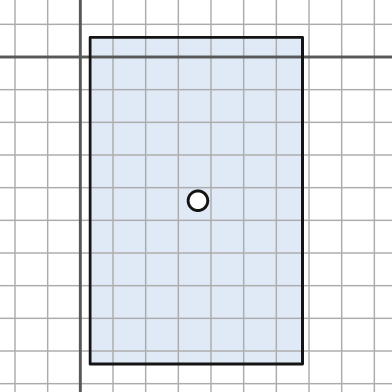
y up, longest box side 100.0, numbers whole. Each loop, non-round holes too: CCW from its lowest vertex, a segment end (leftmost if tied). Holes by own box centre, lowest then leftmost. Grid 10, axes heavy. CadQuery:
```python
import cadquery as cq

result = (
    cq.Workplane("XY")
    .moveTo(3.0, -94.0)
    .lineTo(68.0, -94.0)
    .lineTo(68.0, 6.0)
    .lineTo(3.0, 6.0)
    .close()
    .moveTo(36.0, -44.0)
    .circle(3.0)
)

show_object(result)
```